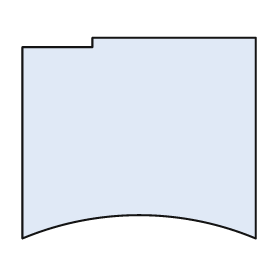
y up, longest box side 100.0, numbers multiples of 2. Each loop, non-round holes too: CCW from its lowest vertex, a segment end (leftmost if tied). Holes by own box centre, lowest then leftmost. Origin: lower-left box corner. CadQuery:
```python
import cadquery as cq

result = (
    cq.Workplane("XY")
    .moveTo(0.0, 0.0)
    .threePointArc((50.0, 10.0), (100.0, 0.0))
    .lineTo(100.0, 86.0)
    .lineTo(30.0, 86.0)
    .lineTo(30.0, 82.0)
    .lineTo(0.0, 82.0)
    .close()
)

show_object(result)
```